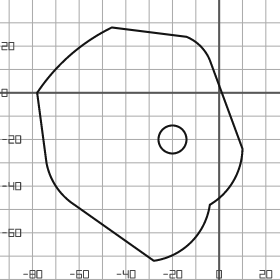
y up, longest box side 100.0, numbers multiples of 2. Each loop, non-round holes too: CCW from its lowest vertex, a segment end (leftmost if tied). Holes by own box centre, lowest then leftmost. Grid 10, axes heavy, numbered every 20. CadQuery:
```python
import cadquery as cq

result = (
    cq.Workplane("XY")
    .moveTo(-28.0, -72.0)
    .threePointArc((-12.0, -64.0), (-4.0, -48.0))
    .threePointArc((6.0, -38.0), (10.0, -24.0))
    .lineTo(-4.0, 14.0)
    .threePointArc((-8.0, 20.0), (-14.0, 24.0))
    .lineTo(-46.0, 28.0)
    .threePointArc((-64.0, 16.0), (-78.0, 0.0))
    .lineTo(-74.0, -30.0)
    .threePointArc((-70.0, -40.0), (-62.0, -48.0))
    .close()
    .moveTo(-20.0, -20.0)
    .circle(6.0)
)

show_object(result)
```